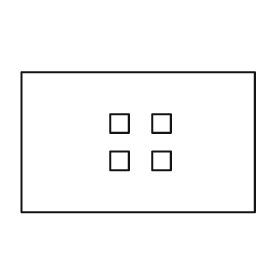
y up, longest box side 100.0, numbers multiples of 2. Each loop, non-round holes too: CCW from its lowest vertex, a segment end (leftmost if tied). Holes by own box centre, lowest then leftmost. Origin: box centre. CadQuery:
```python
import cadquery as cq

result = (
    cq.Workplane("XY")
    .moveTo(-50.0, -30.0)
    .lineTo(50.0, -30.0)
    .lineTo(50.0, 30.0)
    .lineTo(-50.0, 30.0)
    .close()
    .moveTo(-12.0, -12.0)
    .lineTo(-4.0, -12.0)
    .lineTo(-4.0, -4.0)
    .lineTo(-12.0, -4.0)
    .close()
    .moveTo(6.0, -12.0)
    .lineTo(14.0, -12.0)
    .lineTo(14.0, -4.0)
    .lineTo(6.0, -4.0)
    .close()
    .moveTo(-12.0, 4.0)
    .lineTo(-4.0, 4.0)
    .lineTo(-4.0, 12.0)
    .lineTo(-12.0, 12.0)
    .close()
    .moveTo(6.0, 4.0)
    .lineTo(14.0, 4.0)
    .lineTo(14.0, 12.0)
    .lineTo(6.0, 12.0)
    .close()
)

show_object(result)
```